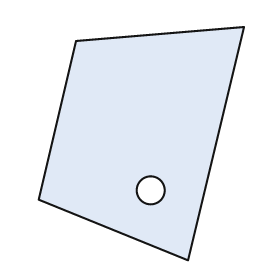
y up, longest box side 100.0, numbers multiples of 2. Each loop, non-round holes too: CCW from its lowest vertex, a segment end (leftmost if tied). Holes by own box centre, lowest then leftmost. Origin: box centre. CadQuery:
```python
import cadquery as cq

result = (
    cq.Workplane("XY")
    .moveTo(20.0, -50.0)
    .lineTo(44.0, 50.0)
    .lineTo(-28.0, 44.0)
    .lineTo(-44.0, -24.0)
    .close()
    .moveTo(4.0, -20.0)
    .circle(6.0)
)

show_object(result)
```